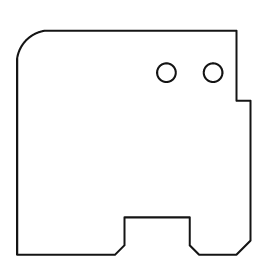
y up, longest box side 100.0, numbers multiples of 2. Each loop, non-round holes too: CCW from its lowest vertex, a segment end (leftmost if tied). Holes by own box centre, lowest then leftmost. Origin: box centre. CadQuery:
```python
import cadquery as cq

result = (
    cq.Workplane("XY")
    .moveTo(-50.0, -48.0)
    .lineTo(-8.0, -48.0)
    .lineTo(-4.0, -44.0)
    .lineTo(-4.0, -32.0)
    .lineTo(24.0, -32.0)
    .lineTo(24.0, -44.0)
    .lineTo(28.0, -48.0)
    .lineTo(44.0, -48.0)
    .lineTo(50.0, -42.0)
    .lineTo(50.0, 18.0)
    .lineTo(44.0, 18.0)
    .lineTo(44.0, 48.0)
    .lineTo(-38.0, 48.0)
    .threePointArc((-46.0, 44.0), (-50.0, 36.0))
    .close()
    .moveTo(14.0, 30.0)
    .circle(4.0)
    .moveTo(34.0, 30.0)
    .circle(4.0)
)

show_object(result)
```